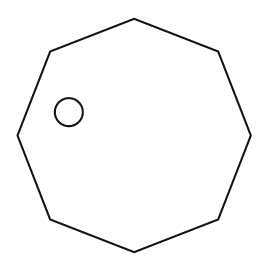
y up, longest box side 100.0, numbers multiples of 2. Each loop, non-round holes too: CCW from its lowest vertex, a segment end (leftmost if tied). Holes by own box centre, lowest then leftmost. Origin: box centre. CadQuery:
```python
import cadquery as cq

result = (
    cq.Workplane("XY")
    .moveTo(0.0, -50.0)
    .lineTo(36.0, -36.0)
    .lineTo(50.0, 0.0)
    .lineTo(36.0, 36.0)
    .lineTo(0.0, 50.0)
    .lineTo(-36.0, 36.0)
    .lineTo(-50.0, 0.0)
    .lineTo(-36.0, -36.0)
    .close()
    .moveTo(-28.0, 10.0)
    .circle(6.0)
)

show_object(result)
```